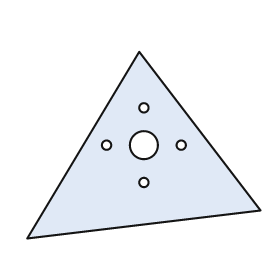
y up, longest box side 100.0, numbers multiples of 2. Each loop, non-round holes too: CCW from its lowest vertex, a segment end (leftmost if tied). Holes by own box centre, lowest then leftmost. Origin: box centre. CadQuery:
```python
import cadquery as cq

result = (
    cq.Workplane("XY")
    .moveTo(-50.0, -40.0)
    .lineTo(50.0, -28.0)
    .lineTo(-2.0, 40.0)
    .close()
    .moveTo(0.0, -16.0)
    .circle(2.0)
    .moveTo(-16.0, 0.0)
    .circle(2.0)
    .moveTo(0.0, 0.0)
    .circle(6.0)
    .moveTo(16.0, 0.0)
    .circle(2.0)
    .moveTo(0.0, 16.0)
    .circle(2.0)
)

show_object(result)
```